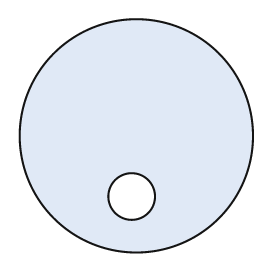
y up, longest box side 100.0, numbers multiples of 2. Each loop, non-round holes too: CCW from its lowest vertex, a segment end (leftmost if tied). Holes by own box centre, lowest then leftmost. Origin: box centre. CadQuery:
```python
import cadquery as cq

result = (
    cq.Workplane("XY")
    .moveTo(0.0, 0.0)
    .circle(50.0)
    .moveTo(-2.0, -26.0)
    .circle(10.0)
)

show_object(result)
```